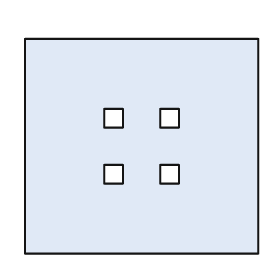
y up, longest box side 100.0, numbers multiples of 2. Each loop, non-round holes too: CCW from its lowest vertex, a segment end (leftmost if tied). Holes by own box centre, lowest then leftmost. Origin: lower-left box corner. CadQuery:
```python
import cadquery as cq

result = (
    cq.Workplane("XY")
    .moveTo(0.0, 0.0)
    .lineTo(100.0, 0.0)
    .lineTo(100.0, 92.0)
    .lineTo(0.0, 92.0)
    .close()
    .moveTo(34.0, 30.0)
    .lineTo(42.0, 30.0)
    .lineTo(42.0, 38.0)
    .lineTo(34.0, 38.0)
    .close()
    .moveTo(58.0, 30.0)
    .lineTo(66.0, 30.0)
    .lineTo(66.0, 38.0)
    .lineTo(58.0, 38.0)
    .close()
    .moveTo(34.0, 54.0)
    .lineTo(42.0, 54.0)
    .lineTo(42.0, 62.0)
    .lineTo(34.0, 62.0)
    .close()
    .moveTo(58.0, 54.0)
    .lineTo(66.0, 54.0)
    .lineTo(66.0, 62.0)
    .lineTo(58.0, 62.0)
    .close()
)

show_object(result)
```